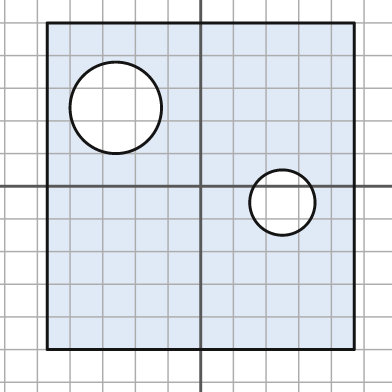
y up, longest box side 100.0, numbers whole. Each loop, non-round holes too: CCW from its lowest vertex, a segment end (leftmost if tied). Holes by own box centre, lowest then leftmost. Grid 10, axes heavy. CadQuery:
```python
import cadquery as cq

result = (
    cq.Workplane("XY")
    .moveTo(-47.0, -50.0)
    .lineTo(47.0, -50.0)
    .lineTo(47.0, 50.0)
    .lineTo(-47.0, 50.0)
    .close()
    .moveTo(25.0, -5.0)
    .circle(10.0)
    .moveTo(-26.0, 24.0)
    .circle(14.0)
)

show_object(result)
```